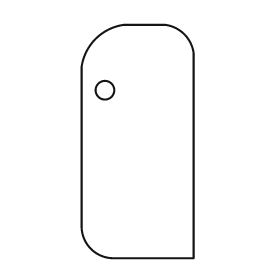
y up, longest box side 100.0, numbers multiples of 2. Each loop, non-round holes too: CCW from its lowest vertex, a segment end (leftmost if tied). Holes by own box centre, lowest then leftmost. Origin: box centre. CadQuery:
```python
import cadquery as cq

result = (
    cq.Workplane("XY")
    .moveTo(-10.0, -50.0)
    .lineTo(24.0, -50.0)
    .lineTo(24.0, 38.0)
    .threePointArc((20.0, 46.0), (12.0, 50.0))
    .lineTo(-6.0, 50.0)
    .threePointArc((-18.0, 44.0), (-24.0, 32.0))
    .lineTo(-24.0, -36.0)
    .threePointArc((-20.0, -46.0), (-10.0, -50.0))
    .close()
    .moveTo(-14.0, 22.0)
    .circle(4.0)
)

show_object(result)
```